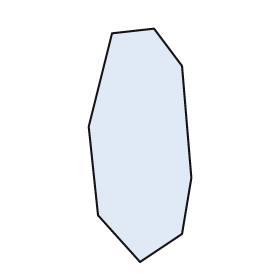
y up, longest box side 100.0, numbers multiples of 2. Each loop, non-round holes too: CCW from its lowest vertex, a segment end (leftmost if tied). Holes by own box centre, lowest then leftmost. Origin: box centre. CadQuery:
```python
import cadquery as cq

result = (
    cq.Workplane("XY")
    .moveTo(0.0, -50.0)
    .lineTo(18.0, -38.0)
    .lineTo(22.0, -14.0)
    .lineTo(18.0, 34.0)
    .lineTo(6.0, 50.0)
    .lineTo(-12.0, 48.0)
    .lineTo(-22.0, 8.0)
    .lineTo(-18.0, -30.0)
    .close()
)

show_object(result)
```